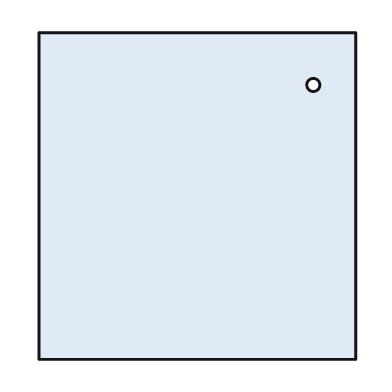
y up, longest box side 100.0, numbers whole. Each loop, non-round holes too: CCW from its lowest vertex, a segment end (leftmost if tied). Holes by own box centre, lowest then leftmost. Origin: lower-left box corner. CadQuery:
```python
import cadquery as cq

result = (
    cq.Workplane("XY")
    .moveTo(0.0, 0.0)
    .lineTo(97.0, 0.0)
    .lineTo(97.0, 100.0)
    .lineTo(0.0, 100.0)
    .close()
    .moveTo(84.0, 84.0)
    .circle(2.0)
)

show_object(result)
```